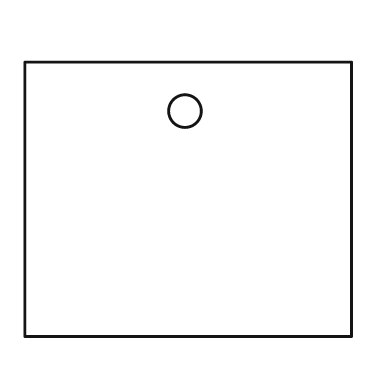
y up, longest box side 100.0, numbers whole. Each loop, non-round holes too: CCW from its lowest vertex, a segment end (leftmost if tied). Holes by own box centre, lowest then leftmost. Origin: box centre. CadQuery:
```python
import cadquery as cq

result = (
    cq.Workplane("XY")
    .moveTo(-50.0, -42.0)
    .lineTo(50.0, -42.0)
    .lineTo(50.0, 42.0)
    .lineTo(-50.0, 42.0)
    .close()
    .moveTo(-1.0, 27.0)
    .circle(5.0)
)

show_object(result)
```